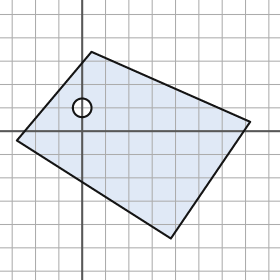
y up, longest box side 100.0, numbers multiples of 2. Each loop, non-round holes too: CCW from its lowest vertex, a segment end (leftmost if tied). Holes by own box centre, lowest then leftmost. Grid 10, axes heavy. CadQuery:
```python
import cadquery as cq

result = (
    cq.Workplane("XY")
    .moveTo(38.0, -46.0)
    .lineTo(72.0, 4.0)
    .lineTo(4.0, 34.0)
    .lineTo(-28.0, -4.0)
    .close()
    .moveTo(0.0, 10.0)
    .circle(4.0)
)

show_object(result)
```